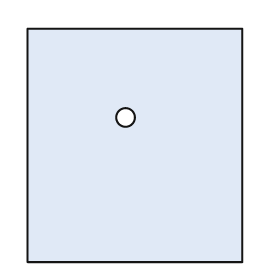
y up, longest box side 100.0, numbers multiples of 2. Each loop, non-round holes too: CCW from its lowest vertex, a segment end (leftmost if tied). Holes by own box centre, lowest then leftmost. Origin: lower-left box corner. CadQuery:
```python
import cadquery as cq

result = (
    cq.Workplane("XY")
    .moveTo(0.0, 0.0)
    .lineTo(92.0, 0.0)
    .lineTo(92.0, 100.0)
    .lineTo(0.0, 100.0)
    .close()
    .moveTo(42.0, 62.0)
    .circle(4.0)
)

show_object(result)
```